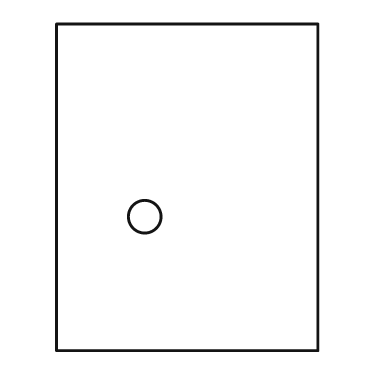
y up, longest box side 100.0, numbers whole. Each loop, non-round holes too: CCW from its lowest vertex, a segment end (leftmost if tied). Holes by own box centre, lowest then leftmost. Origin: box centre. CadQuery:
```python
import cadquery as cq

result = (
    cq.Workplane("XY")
    .moveTo(-40.0, -50.0)
    .lineTo(40.0, -50.0)
    .lineTo(40.0, 50.0)
    .lineTo(-40.0, 50.0)
    .close()
    .moveTo(-13.0, -9.0)
    .circle(5.0)
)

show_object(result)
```